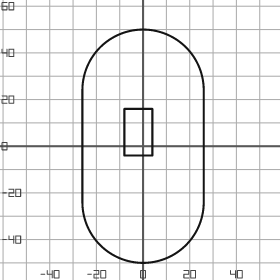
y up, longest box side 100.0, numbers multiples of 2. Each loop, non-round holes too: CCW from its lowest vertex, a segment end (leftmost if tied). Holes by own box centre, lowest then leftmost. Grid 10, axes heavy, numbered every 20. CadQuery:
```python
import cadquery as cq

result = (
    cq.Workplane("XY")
    .moveTo(-26.0, -24.0)
    .threePointArc((0.0, -50.0), (26.0, -24.0))
    .lineTo(26.0, 24.0)
    .threePointArc((0.0, 50.0), (-26.0, 24.0))
    .close()
    .moveTo(-8.0, -4.0)
    .lineTo(4.0, -4.0)
    .lineTo(4.0, 16.0)
    .lineTo(-8.0, 16.0)
    .close()
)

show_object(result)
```